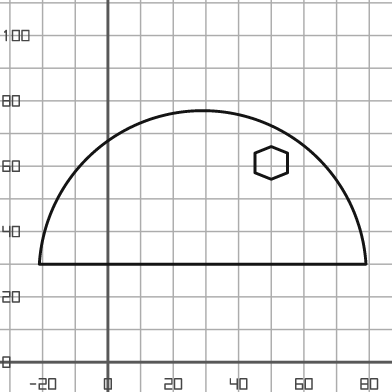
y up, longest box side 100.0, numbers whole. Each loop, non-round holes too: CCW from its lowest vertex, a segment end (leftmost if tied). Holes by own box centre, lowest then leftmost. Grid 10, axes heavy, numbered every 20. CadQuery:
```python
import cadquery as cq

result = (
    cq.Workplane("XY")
    .moveTo(-21.0, 30.0)
    .lineTo(79.0, 30.0)
    .threePointArc((29.0, 77.0), (-21.0, 30.0))
    .close()
    .moveTo(50.0, 56.0)
    .lineTo(55.0, 58.0)
    .lineTo(55.0, 64.0)
    .lineTo(50.0, 66.0)
    .lineTo(45.0, 64.0)
    .lineTo(45.0, 58.0)
    .close()
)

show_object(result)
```